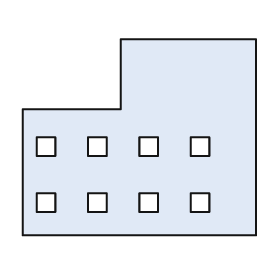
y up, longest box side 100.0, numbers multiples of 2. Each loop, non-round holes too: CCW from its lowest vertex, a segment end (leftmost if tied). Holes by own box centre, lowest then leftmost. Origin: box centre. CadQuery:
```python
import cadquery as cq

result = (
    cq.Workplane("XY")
    .moveTo(-50.0, -42.0)
    .lineTo(50.0, -42.0)
    .lineTo(50.0, 42.0)
    .lineTo(-8.0, 42.0)
    .lineTo(-8.0, 12.0)
    .lineTo(-50.0, 12.0)
    .close()
    .moveTo(-44.0, -32.0)
    .lineTo(-36.0, -32.0)
    .lineTo(-36.0, -24.0)
    .lineTo(-44.0, -24.0)
    .close()
    .moveTo(-22.0, -32.0)
    .lineTo(-14.0, -32.0)
    .lineTo(-14.0, -24.0)
    .lineTo(-22.0, -24.0)
    .close()
    .moveTo(0.0, -32.0)
    .lineTo(8.0, -32.0)
    .lineTo(8.0, -24.0)
    .lineTo(0.0, -24.0)
    .close()
    .moveTo(22.0, -32.0)
    .lineTo(30.0, -32.0)
    .lineTo(30.0, -24.0)
    .lineTo(22.0, -24.0)
    .close()
    .moveTo(-44.0, -8.0)
    .lineTo(-36.0, -8.0)
    .lineTo(-36.0, 0.0)
    .lineTo(-44.0, 0.0)
    .close()
    .moveTo(-22.0, -8.0)
    .lineTo(-14.0, -8.0)
    .lineTo(-14.0, 0.0)
    .lineTo(-22.0, 0.0)
    .close()
    .moveTo(0.0, -8.0)
    .lineTo(8.0, -8.0)
    .lineTo(8.0, 0.0)
    .lineTo(0.0, 0.0)
    .close()
    .moveTo(22.0, -8.0)
    .lineTo(30.0, -8.0)
    .lineTo(30.0, 0.0)
    .lineTo(22.0, 0.0)
    .close()
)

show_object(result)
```